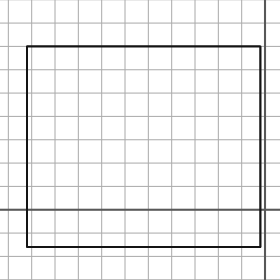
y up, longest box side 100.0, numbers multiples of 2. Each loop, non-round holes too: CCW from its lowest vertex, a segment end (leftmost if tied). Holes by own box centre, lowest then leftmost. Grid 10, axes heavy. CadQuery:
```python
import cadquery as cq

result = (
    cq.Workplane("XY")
    .moveTo(-102.0, -16.0)
    .lineTo(-2.0, -16.0)
    .lineTo(-2.0, 70.0)
    .lineTo(-102.0, 70.0)
    .close()
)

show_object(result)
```